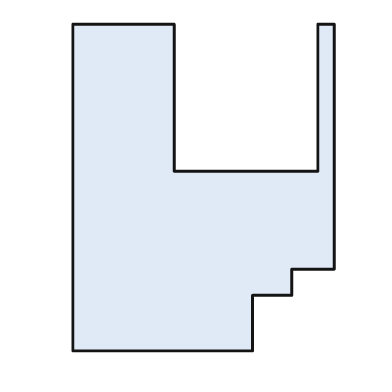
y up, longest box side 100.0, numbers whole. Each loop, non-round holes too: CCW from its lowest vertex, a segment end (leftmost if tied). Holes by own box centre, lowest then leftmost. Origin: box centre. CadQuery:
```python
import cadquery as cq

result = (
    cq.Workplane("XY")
    .moveTo(-40.0, -50.0)
    .lineTo(15.0, -50.0)
    .lineTo(15.0, -33.0)
    .lineTo(27.0, -33.0)
    .lineTo(27.0, -25.0)
    .lineTo(40.0, -25.0)
    .lineTo(40.0, 50.0)
    .lineTo(35.0, 50.0)
    .lineTo(35.0, 5.0)
    .lineTo(-9.0, 5.0)
    .lineTo(-9.0, 50.0)
    .lineTo(-40.0, 50.0)
    .close()
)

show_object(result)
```